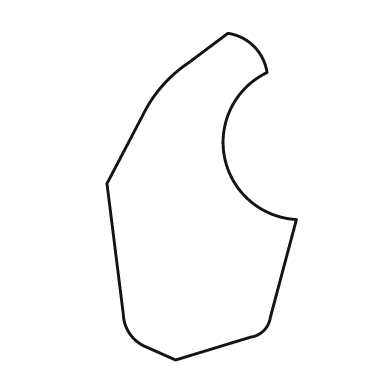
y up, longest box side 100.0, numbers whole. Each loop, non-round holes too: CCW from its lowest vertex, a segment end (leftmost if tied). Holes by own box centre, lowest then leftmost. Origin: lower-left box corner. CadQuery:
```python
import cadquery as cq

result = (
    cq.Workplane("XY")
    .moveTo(21.0, 0.0)
    .lineTo(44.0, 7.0)
    .threePointArc((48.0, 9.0), (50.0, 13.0))
    .lineTo(58.0, 43.0)
    .threePointArc((36.0, 62.0), (49.0, 88.0))
    .threePointArc((45.0, 96.0), (37.0, 100.0))
    .lineTo(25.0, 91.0)
    .threePointArc((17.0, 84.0), (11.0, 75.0))
    .lineTo(0.0, 54.0)
    .lineTo(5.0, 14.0)
    .threePointArc((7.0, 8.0), (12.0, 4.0))
    .close()
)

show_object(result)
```